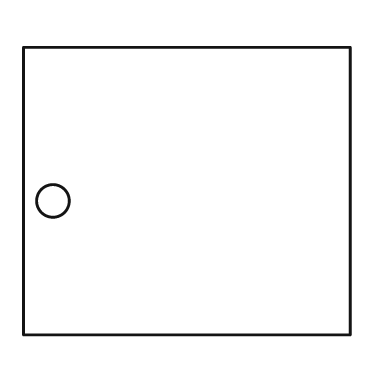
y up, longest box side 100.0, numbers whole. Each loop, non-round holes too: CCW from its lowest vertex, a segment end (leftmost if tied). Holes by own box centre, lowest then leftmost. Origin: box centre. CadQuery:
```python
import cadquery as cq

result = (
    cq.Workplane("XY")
    .moveTo(-50.0, -44.0)
    .lineTo(50.0, -44.0)
    .lineTo(50.0, 44.0)
    .lineTo(-50.0, 44.0)
    .close()
    .moveTo(-41.0, -3.0)
    .circle(5.0)
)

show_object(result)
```